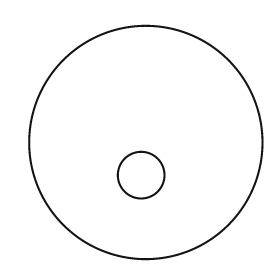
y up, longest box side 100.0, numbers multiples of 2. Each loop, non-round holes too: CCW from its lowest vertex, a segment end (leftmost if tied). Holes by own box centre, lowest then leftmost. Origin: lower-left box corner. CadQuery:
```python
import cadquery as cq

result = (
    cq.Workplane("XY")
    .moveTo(50.0, 50.0)
    .circle(50.0)
    .moveTo(48.0, 36.0)
    .circle(10.0)
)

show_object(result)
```